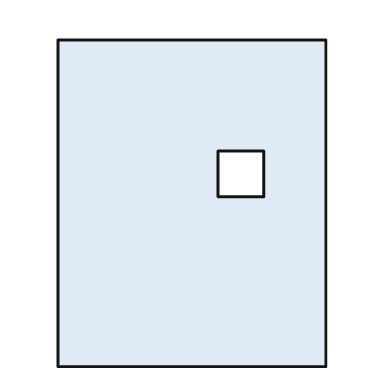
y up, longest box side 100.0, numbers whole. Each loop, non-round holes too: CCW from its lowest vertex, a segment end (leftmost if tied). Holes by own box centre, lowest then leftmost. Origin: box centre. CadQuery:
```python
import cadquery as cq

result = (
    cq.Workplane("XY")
    .moveTo(-41.0, -50.0)
    .lineTo(41.0, -50.0)
    .lineTo(41.0, 50.0)
    .lineTo(-41.0, 50.0)
    .close()
    .moveTo(8.0, 2.0)
    .lineTo(22.0, 2.0)
    .lineTo(22.0, 16.0)
    .lineTo(8.0, 16.0)
    .close()
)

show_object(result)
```